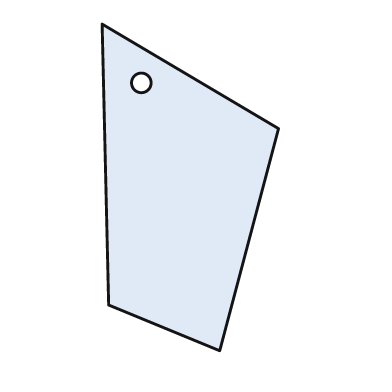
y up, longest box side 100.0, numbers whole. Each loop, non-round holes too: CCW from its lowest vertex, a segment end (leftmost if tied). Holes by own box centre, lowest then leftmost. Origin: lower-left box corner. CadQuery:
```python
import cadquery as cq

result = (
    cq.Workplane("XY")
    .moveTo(36.0, 0.0)
    .lineTo(54.0, 68.0)
    .lineTo(0.0, 100.0)
    .lineTo(2.0, 14.0)
    .close()
    .moveTo(12.0, 82.0)
    .circle(3.0)
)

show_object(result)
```